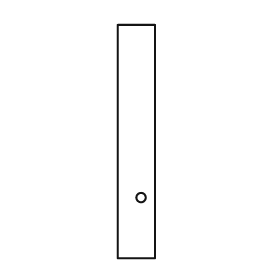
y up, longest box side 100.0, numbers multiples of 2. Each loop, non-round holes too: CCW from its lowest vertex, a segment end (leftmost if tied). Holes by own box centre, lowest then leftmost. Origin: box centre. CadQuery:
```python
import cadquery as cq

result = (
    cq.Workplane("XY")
    .moveTo(-8.0, -50.0)
    .lineTo(8.0, -50.0)
    .lineTo(8.0, 50.0)
    .lineTo(-8.0, 50.0)
    .close()
    .moveTo(2.0, -24.0)
    .circle(2.0)
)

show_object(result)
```